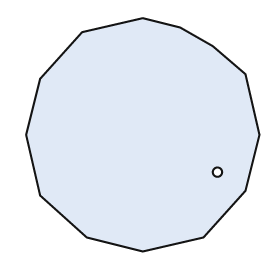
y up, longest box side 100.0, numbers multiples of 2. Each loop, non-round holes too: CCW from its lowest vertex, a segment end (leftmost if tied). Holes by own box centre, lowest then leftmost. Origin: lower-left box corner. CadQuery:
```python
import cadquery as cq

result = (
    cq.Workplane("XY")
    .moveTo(50.0, 0.0)
    .lineTo(76.0, 6.0)
    .lineTo(94.0, 26.0)
    .lineTo(100.0, 50.0)
    .lineTo(94.0, 76.0)
    .lineTo(80.0, 88.0)
    .lineTo(66.0, 96.0)
    .lineTo(50.0, 100.0)
    .lineTo(24.0, 94.0)
    .lineTo(6.0, 74.0)
    .lineTo(0.0, 50.0)
    .lineTo(6.0, 24.0)
    .lineTo(26.0, 6.0)
    .close()
    .moveTo(82.0, 34.0)
    .circle(2.0)
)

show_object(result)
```